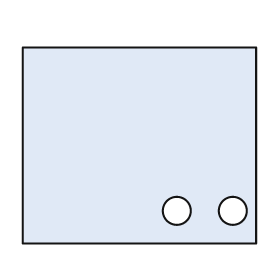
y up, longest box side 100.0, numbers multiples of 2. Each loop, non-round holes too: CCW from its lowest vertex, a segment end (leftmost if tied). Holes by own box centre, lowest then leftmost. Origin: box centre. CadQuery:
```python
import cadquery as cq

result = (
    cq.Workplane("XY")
    .moveTo(-50.0, -42.0)
    .lineTo(50.0, -42.0)
    .lineTo(50.0, 42.0)
    .lineTo(-50.0, 42.0)
    .close()
    .moveTo(16.0, -28.0)
    .circle(6.0)
    .moveTo(40.0, -28.0)
    .circle(6.0)
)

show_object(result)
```